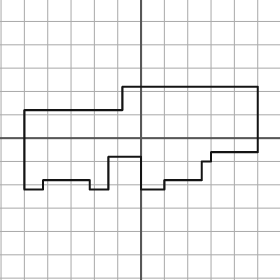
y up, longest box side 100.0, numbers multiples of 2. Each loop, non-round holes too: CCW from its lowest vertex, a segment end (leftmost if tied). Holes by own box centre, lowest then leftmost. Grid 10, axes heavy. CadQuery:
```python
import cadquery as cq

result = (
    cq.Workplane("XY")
    .moveTo(-50.0, -22.0)
    .lineTo(-42.0, -22.0)
    .lineTo(-42.0, -18.0)
    .lineTo(-22.0, -18.0)
    .lineTo(-22.0, -22.0)
    .lineTo(-14.0, -22.0)
    .lineTo(-14.0, -8.0)
    .lineTo(0.0, -8.0)
    .lineTo(0.0, -22.0)
    .lineTo(10.0, -22.0)
    .lineTo(10.0, -18.0)
    .lineTo(26.0, -18.0)
    .lineTo(26.0, -10.0)
    .lineTo(30.0, -10.0)
    .lineTo(30.0, -6.0)
    .lineTo(50.0, -6.0)
    .lineTo(50.0, 22.0)
    .lineTo(-8.0, 22.0)
    .lineTo(-8.0, 12.0)
    .lineTo(-50.0, 12.0)
    .close()
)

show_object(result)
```